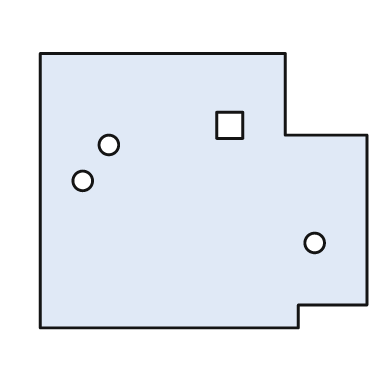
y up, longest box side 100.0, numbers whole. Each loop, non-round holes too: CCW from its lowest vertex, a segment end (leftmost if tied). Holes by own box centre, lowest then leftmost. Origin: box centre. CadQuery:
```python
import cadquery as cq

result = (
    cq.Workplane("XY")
    .moveTo(-50.0, -42.0)
    .lineTo(29.0, -42.0)
    .lineTo(29.0, -35.0)
    .lineTo(50.0, -35.0)
    .lineTo(50.0, 17.0)
    .lineTo(25.0, 17.0)
    .lineTo(25.0, 42.0)
    .lineTo(-50.0, 42.0)
    .close()
    .moveTo(34.0, -16.0)
    .circle(3.0)
    .moveTo(-37.0, 3.0)
    .circle(3.0)
    .moveTo(-29.0, 14.0)
    .circle(3.0)
    .moveTo(4.0, 16.0)
    .lineTo(12.0, 16.0)
    .lineTo(12.0, 24.0)
    .lineTo(4.0, 24.0)
    .close()
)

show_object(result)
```